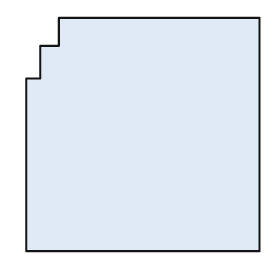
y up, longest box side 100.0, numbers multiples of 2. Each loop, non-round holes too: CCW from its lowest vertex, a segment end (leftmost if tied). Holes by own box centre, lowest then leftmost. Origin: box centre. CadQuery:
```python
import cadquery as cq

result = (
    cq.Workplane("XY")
    .moveTo(-50.0, -50.0)
    .lineTo(50.0, -50.0)
    .lineTo(50.0, 50.0)
    .lineTo(-36.0, 50.0)
    .lineTo(-36.0, 38.0)
    .lineTo(-44.0, 38.0)
    .lineTo(-44.0, 24.0)
    .lineTo(-50.0, 24.0)
    .close()
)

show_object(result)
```